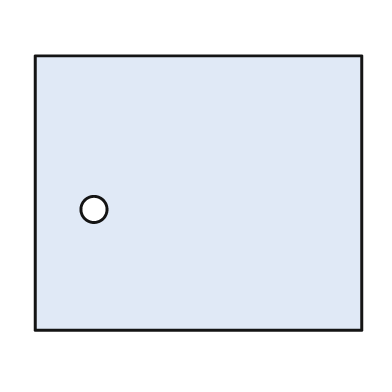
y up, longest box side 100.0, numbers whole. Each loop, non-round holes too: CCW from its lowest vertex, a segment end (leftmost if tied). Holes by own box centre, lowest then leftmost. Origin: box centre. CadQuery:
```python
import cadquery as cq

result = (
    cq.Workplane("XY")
    .moveTo(-50.0, -42.0)
    .lineTo(50.0, -42.0)
    .lineTo(50.0, 42.0)
    .lineTo(-50.0, 42.0)
    .close()
    .moveTo(-32.0, -5.0)
    .circle(4.0)
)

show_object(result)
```